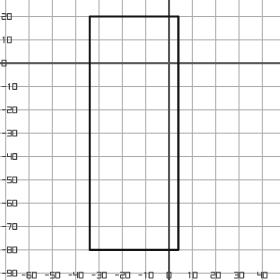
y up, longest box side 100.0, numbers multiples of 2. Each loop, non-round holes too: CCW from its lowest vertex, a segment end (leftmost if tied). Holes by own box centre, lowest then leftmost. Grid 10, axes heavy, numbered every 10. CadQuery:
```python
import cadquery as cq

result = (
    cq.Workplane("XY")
    .moveTo(-34.0, -80.0)
    .lineTo(4.0, -80.0)
    .lineTo(4.0, 20.0)
    .lineTo(-34.0, 20.0)
    .close()
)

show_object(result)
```